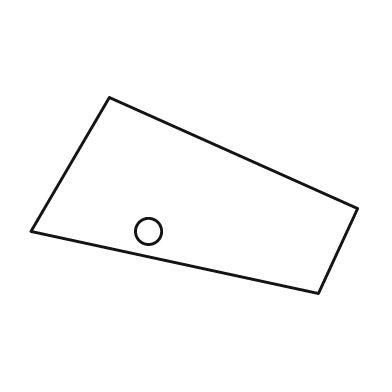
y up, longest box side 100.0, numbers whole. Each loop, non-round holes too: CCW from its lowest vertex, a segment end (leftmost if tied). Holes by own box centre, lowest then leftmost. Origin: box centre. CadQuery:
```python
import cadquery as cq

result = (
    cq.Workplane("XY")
    .moveTo(38.0, -30.0)
    .lineTo(50.0, -4.0)
    .lineTo(-26.0, 30.0)
    .lineTo(-50.0, -11.0)
    .close()
    .moveTo(-14.0, -11.0)
    .circle(4.0)
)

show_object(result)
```